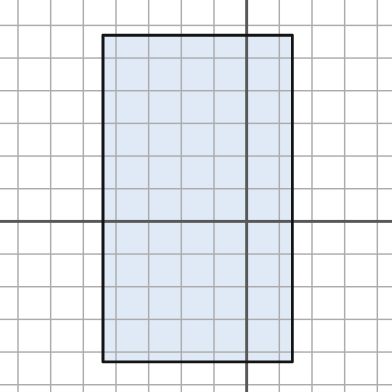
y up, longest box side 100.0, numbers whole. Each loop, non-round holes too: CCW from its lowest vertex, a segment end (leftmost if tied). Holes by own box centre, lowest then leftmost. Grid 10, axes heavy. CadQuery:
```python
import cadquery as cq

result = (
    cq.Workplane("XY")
    .moveTo(-44.0, -43.0)
    .lineTo(14.0, -43.0)
    .lineTo(14.0, 57.0)
    .lineTo(-44.0, 57.0)
    .close()
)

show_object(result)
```